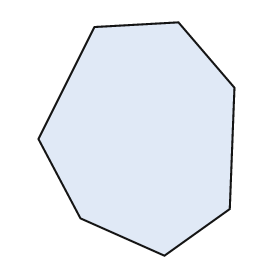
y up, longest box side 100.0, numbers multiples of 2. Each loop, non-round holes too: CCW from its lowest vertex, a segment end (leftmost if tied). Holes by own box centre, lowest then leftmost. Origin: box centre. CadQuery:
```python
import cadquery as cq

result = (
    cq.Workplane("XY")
    .moveTo(12.0, -50.0)
    .lineTo(40.0, -30.0)
    .lineTo(42.0, 22.0)
    .lineTo(18.0, 50.0)
    .lineTo(-18.0, 48.0)
    .lineTo(-42.0, 0.0)
    .lineTo(-24.0, -34.0)
    .close()
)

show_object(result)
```